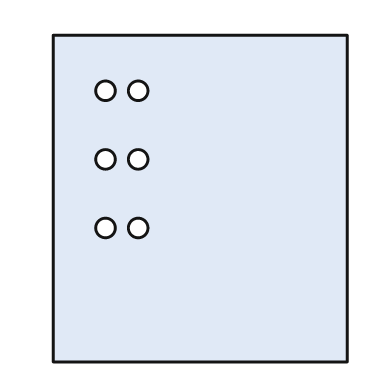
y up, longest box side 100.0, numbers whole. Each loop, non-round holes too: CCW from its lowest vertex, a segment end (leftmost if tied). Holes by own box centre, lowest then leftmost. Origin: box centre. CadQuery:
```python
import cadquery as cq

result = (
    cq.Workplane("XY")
    .moveTo(-45.0, -50.0)
    .lineTo(45.0, -50.0)
    .lineTo(45.0, 50.0)
    .lineTo(-45.0, 50.0)
    .close()
    .moveTo(-29.0, -9.0)
    .circle(3.0)
    .moveTo(-19.0, -9.0)
    .circle(3.0)
    .moveTo(-29.0, 12.0)
    .circle(3.0)
    .moveTo(-19.0, 12.0)
    .circle(3.0)
    .moveTo(-29.0, 33.0)
    .circle(3.0)
    .moveTo(-19.0, 33.0)
    .circle(3.0)
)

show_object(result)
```